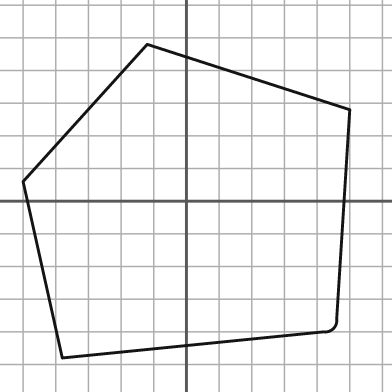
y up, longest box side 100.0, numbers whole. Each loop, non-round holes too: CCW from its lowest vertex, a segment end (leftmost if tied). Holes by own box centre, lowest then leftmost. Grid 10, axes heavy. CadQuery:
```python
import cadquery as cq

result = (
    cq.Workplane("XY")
    .moveTo(-38.0, -48.0)
    .lineTo(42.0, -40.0)
    .threePointArc((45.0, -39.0), (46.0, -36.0))
    .lineTo(50.0, 28.0)
    .lineTo(-12.0, 48.0)
    .lineTo(-50.0, 6.0)
    .close()
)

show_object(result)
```